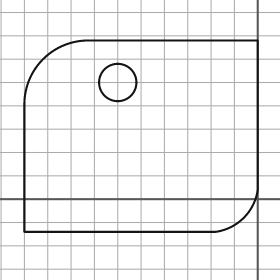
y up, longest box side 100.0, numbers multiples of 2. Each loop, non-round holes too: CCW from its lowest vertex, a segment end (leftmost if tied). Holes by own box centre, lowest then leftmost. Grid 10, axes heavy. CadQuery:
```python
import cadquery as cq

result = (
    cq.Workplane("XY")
    .moveTo(-100.0, -14.0)
    .lineTo(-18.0, -14.0)
    .threePointArc((-6.0, -8.0), (0.0, 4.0))
    .lineTo(0.0, 68.0)
    .lineTo(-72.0, 68.0)
    .threePointArc((-92.0, 60.0), (-100.0, 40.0))
    .close()
    .moveTo(-60.0, 50.0)
    .circle(8.0)
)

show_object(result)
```